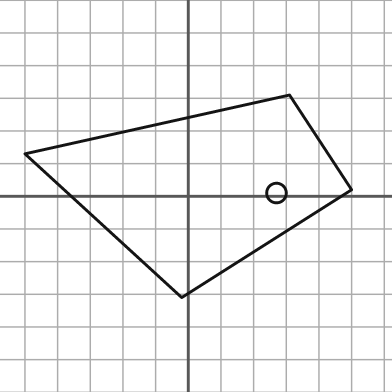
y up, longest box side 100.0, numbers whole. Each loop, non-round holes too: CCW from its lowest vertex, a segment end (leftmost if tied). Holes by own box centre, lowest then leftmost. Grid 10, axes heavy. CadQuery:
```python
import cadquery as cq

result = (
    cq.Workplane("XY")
    .moveTo(-2.0, -31.0)
    .lineTo(50.0, 2.0)
    .lineTo(31.0, 31.0)
    .lineTo(-50.0, 13.0)
    .close()
    .moveTo(27.0, 1.0)
    .circle(3.0)
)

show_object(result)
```